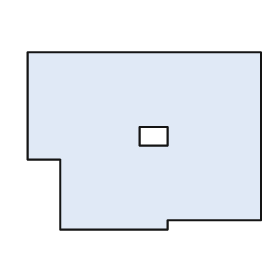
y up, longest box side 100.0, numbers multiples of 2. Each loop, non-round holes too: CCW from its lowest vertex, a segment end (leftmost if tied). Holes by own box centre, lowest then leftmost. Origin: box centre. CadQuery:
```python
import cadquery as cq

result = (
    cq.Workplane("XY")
    .moveTo(-36.0, -38.0)
    .lineTo(10.0, -38.0)
    .lineTo(10.0, -34.0)
    .lineTo(50.0, -34.0)
    .lineTo(50.0, 38.0)
    .lineTo(-50.0, 38.0)
    .lineTo(-50.0, -8.0)
    .lineTo(-36.0, -8.0)
    .close()
    .moveTo(-2.0, -2.0)
    .lineTo(10.0, -2.0)
    .lineTo(10.0, 6.0)
    .lineTo(-2.0, 6.0)
    .close()
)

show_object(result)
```